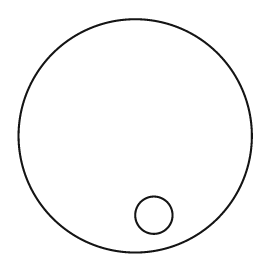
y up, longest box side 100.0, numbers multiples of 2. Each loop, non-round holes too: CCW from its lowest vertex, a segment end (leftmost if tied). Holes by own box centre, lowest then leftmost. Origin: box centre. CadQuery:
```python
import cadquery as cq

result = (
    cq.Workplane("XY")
    .moveTo(0.0, 0.0)
    .circle(50.0)
    .moveTo(8.0, -34.0)
    .circle(8.0)
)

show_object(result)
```